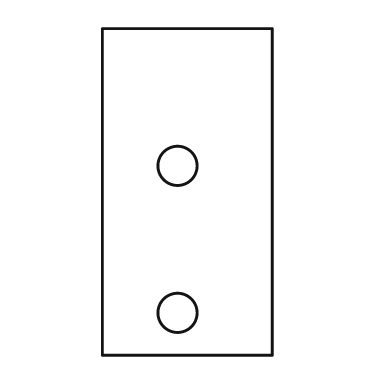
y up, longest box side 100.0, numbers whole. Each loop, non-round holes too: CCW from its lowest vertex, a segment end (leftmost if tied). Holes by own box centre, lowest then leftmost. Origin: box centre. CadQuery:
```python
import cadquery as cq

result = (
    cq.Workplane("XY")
    .moveTo(-26.0, -50.0)
    .lineTo(26.0, -50.0)
    .lineTo(26.0, 50.0)
    .lineTo(-26.0, 50.0)
    .close()
    .moveTo(-3.0, -37.0)
    .circle(6.0)
    .moveTo(-3.0, 8.0)
    .circle(6.0)
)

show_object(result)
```